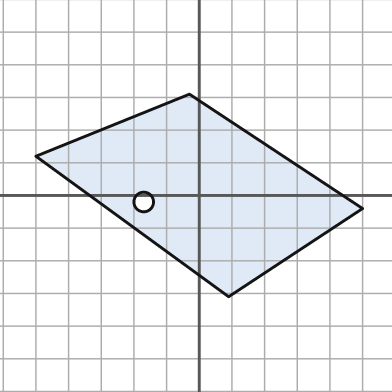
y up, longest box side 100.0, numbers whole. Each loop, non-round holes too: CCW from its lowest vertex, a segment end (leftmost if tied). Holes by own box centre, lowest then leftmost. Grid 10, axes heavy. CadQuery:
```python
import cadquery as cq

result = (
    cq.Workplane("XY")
    .moveTo(9.0, -31.0)
    .lineTo(50.0, -4.0)
    .lineTo(-3.0, 31.0)
    .lineTo(-50.0, 12.0)
    .close()
    .moveTo(-17.0, -2.0)
    .circle(3.0)
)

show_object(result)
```